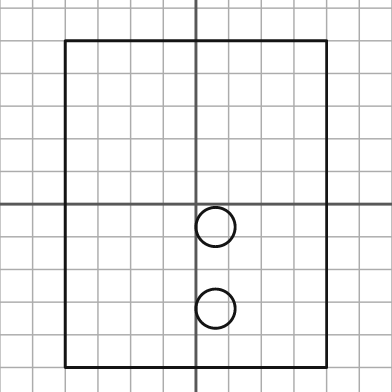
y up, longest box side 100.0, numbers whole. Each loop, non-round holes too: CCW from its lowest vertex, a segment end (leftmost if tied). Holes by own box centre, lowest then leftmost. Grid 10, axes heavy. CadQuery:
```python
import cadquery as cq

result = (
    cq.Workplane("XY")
    .moveTo(-40.0, -50.0)
    .lineTo(40.0, -50.0)
    .lineTo(40.0, 50.0)
    .lineTo(-40.0, 50.0)
    .close()
    .moveTo(6.0, -32.0)
    .circle(6.0)
    .moveTo(6.0, -7.0)
    .circle(6.0)
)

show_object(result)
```